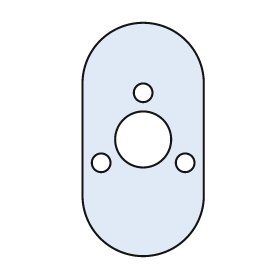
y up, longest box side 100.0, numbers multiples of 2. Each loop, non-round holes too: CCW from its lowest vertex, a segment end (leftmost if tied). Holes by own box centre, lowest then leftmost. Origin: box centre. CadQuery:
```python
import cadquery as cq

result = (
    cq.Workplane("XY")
    .moveTo(-26.0, -24.0)
    .threePointArc((0.0, -50.0), (26.0, -24.0))
    .lineTo(26.0, 24.0)
    .threePointArc((0.0, 50.0), (-26.0, 24.0))
    .close()
    .moveTo(-18.0, -10.0)
    .circle(4.0)
    .moveTo(18.0, -10.0)
    .circle(4.0)
    .moveTo(0.0, 0.0)
    .circle(12.0)
    .moveTo(0.0, 20.0)
    .circle(4.0)
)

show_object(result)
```